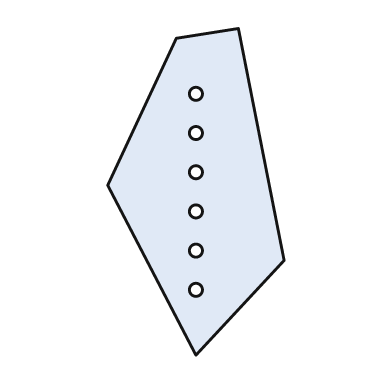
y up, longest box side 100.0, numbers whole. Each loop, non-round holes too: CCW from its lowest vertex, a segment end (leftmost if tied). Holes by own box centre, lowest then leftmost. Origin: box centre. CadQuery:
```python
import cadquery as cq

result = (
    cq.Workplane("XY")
    .moveTo(0.0, -50.0)
    .lineTo(27.0, -21.0)
    .lineTo(13.0, 50.0)
    .lineTo(-6.0, 47.0)
    .lineTo(-27.0, 2.0)
    .close()
    .moveTo(0.0, -30.0)
    .circle(2.0)
    .moveTo(0.0, -18.0)
    .circle(2.0)
    .moveTo(0.0, -6.0)
    .circle(2.0)
    .moveTo(0.0, 6.0)
    .circle(2.0)
    .moveTo(0.0, 18.0)
    .circle(2.0)
    .moveTo(0.0, 30.0)
    .circle(2.0)
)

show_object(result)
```